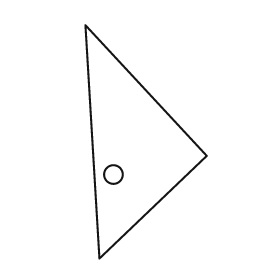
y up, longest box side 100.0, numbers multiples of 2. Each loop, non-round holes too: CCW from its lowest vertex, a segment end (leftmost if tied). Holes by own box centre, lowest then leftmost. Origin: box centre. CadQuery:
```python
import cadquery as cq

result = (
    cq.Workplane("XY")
    .moveTo(-20.0, -50.0)
    .lineTo(26.0, -6.0)
    .lineTo(-26.0, 50.0)
    .close()
    .moveTo(-14.0, -14.0)
    .circle(4.0)
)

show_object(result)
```